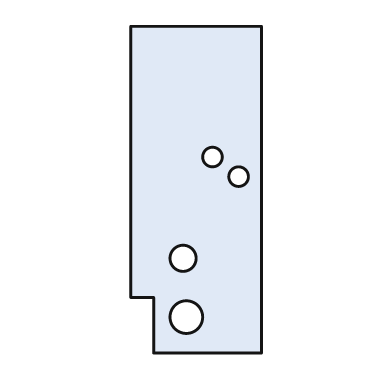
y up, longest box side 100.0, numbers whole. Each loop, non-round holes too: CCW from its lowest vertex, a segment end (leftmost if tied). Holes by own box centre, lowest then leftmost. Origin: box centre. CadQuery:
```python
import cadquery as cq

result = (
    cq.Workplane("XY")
    .moveTo(-13.0, -50.0)
    .lineTo(20.0, -50.0)
    .lineTo(20.0, 50.0)
    .lineTo(-20.0, 50.0)
    .lineTo(-20.0, -33.0)
    .lineTo(-13.0, -33.0)
    .close()
    .moveTo(-3.0, -39.0)
    .circle(5.0)
    .moveTo(-4.0, -21.0)
    .circle(4.0)
    .moveTo(13.0, 4.0)
    .circle(3.0)
    .moveTo(5.0, 10.0)
    .circle(3.0)
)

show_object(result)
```